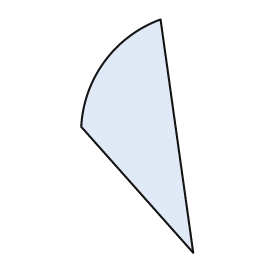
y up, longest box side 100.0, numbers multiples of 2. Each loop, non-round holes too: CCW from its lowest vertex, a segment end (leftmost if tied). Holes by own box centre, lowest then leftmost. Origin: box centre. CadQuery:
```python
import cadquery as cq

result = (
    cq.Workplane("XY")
    .moveTo(24.0, -50.0)
    .lineTo(10.0, 50.0)
    .threePointArc((-14.0, 32.0), (-24.0, 4.0))
    .close()
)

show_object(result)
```